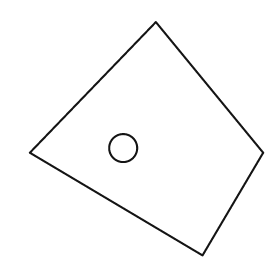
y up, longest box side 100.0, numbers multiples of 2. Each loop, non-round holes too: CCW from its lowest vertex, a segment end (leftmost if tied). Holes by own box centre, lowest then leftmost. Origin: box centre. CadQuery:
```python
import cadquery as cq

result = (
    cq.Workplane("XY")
    .moveTo(24.0, -50.0)
    .lineTo(50.0, -6.0)
    .lineTo(4.0, 50.0)
    .lineTo(-50.0, -6.0)
    .close()
    .moveTo(-10.0, -4.0)
    .circle(6.0)
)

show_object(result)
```